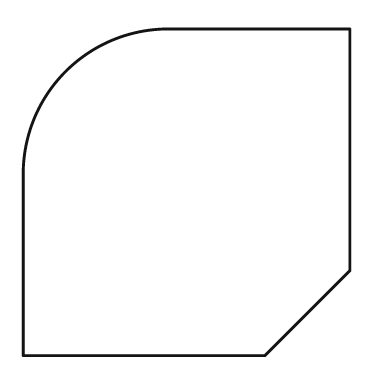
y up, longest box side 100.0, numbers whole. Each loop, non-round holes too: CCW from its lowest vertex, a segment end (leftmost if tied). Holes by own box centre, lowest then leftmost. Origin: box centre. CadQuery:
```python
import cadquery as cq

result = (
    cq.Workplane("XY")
    .moveTo(-50.0, -50.0)
    .lineTo(24.0, -50.0)
    .lineTo(50.0, -24.0)
    .lineTo(50.0, 50.0)
    .lineTo(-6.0, 50.0)
    .threePointArc((-37.0, 37.0), (-50.0, 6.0))
    .close()
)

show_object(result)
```